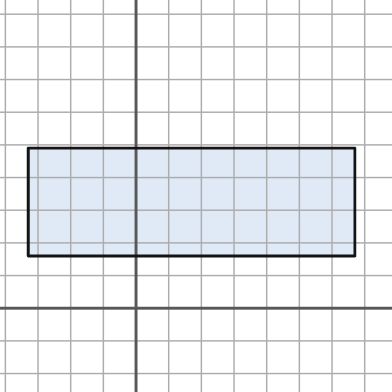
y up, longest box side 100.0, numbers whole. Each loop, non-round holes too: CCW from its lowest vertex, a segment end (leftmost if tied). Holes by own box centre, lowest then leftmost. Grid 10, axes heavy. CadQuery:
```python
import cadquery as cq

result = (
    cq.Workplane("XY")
    .moveTo(-33.0, 16.0)
    .lineTo(67.0, 16.0)
    .lineTo(67.0, 49.0)
    .lineTo(-33.0, 49.0)
    .close()
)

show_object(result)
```